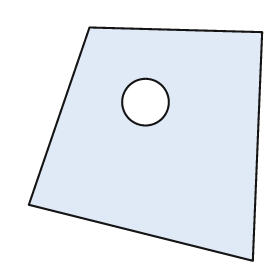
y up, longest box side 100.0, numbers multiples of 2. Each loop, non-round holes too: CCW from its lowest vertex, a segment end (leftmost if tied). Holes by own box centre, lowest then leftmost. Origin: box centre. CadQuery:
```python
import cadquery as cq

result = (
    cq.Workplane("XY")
    .moveTo(46.0, -50.0)
    .lineTo(50.0, 48.0)
    .lineTo(-24.0, 50.0)
    .lineTo(-50.0, -26.0)
    .close()
    .moveTo(0.0, 18.0)
    .circle(10.0)
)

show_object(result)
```